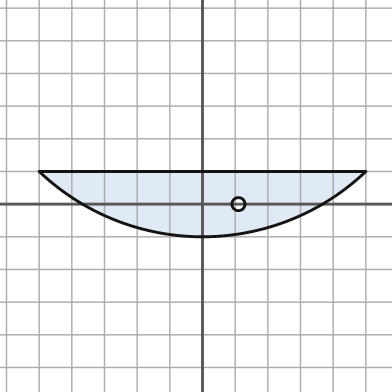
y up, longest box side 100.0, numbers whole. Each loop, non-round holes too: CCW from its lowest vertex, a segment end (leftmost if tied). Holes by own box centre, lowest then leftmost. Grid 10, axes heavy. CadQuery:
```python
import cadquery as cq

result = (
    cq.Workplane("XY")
    .moveTo(-50.0, 10.0)
    .threePointArc((0.0, -10.0), (50.0, 10.0))
    .close()
    .moveTo(11.0, 0.0)
    .circle(2.0)
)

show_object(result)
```